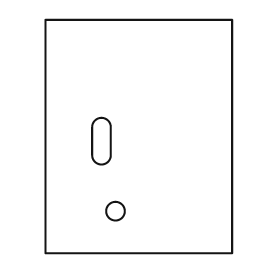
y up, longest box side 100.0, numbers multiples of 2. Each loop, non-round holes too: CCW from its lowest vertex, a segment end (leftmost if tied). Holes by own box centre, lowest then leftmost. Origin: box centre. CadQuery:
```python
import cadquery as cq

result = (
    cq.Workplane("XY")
    .moveTo(-40.0, -50.0)
    .lineTo(40.0, -50.0)
    .lineTo(40.0, 50.0)
    .lineTo(-40.0, 50.0)
    .close()
    .moveTo(-10.0, -32.0)
    .circle(4.0)
    .moveTo(-20.0, -8.0)
    .threePointArc((-16.0, -12.0), (-12.0, -8.0))
    .lineTo(-12.0, 4.0)
    .threePointArc((-16.0, 8.0), (-20.0, 4.0))
    .close()
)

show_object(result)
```